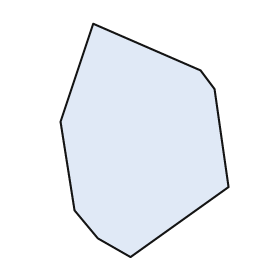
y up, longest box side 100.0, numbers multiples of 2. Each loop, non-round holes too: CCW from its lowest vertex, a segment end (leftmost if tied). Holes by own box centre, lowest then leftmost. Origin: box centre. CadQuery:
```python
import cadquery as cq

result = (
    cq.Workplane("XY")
    .moveTo(-6.0, -50.0)
    .lineTo(36.0, -20.0)
    .lineTo(30.0, 22.0)
    .lineTo(24.0, 30.0)
    .lineTo(-22.0, 50.0)
    .lineTo(-36.0, 8.0)
    .lineTo(-30.0, -30.0)
    .lineTo(-20.0, -42.0)
    .close()
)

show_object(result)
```